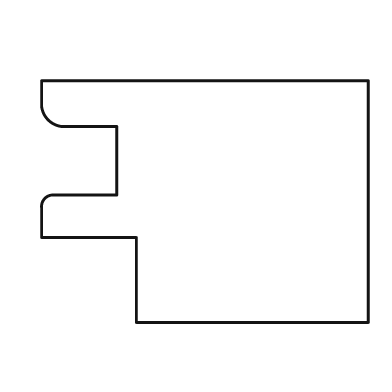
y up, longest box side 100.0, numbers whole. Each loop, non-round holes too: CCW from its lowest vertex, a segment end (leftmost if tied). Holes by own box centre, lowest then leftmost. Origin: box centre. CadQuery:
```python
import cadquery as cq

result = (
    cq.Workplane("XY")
    .moveTo(-21.0, -37.0)
    .lineTo(50.0, -37.0)
    .lineTo(50.0, 37.0)
    .lineTo(-50.0, 37.0)
    .lineTo(-50.0, 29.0)
    .threePointArc((-48.0, 25.0), (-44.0, 23.0))
    .lineTo(-27.0, 23.0)
    .lineTo(-27.0, 2.0)
    .lineTo(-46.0, 2.0)
    .threePointArc((-49.0, 1.0), (-50.0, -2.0))
    .lineTo(-50.0, -11.0)
    .lineTo(-21.0, -11.0)
    .close()
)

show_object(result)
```